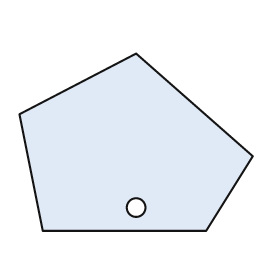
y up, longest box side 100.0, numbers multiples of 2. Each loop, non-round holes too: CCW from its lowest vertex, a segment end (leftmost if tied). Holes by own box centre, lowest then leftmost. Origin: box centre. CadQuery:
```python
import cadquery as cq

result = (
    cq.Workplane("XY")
    .moveTo(-40.0, -38.0)
    .lineTo(30.0, -38.0)
    .lineTo(50.0, -6.0)
    .lineTo(0.0, 38.0)
    .lineTo(-50.0, 12.0)
    .close()
    .moveTo(0.0, -28.0)
    .circle(4.0)
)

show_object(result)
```